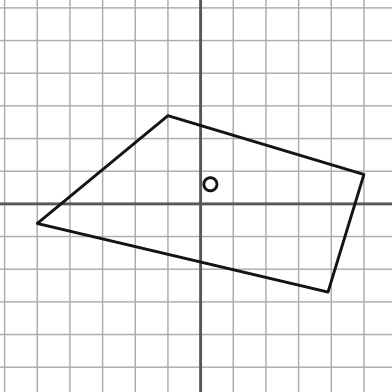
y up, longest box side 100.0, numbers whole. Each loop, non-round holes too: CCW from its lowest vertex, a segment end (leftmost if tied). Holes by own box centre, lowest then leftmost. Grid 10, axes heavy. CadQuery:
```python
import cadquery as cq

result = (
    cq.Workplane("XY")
    .moveTo(39.0, -27.0)
    .lineTo(50.0, 9.0)
    .lineTo(-10.0, 27.0)
    .lineTo(-50.0, -6.0)
    .close()
    .moveTo(3.0, 6.0)
    .circle(2.0)
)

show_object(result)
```